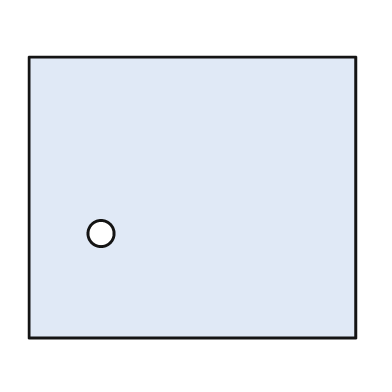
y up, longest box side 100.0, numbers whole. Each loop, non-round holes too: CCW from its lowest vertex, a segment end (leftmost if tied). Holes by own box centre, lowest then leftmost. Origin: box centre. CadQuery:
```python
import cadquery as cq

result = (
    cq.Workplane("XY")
    .moveTo(-50.0, -43.0)
    .lineTo(50.0, -43.0)
    .lineTo(50.0, 43.0)
    .lineTo(-50.0, 43.0)
    .close()
    .moveTo(-28.0, -11.0)
    .circle(4.0)
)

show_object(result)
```